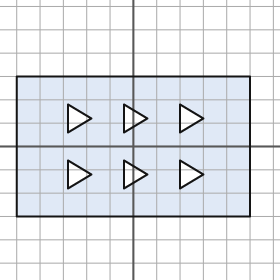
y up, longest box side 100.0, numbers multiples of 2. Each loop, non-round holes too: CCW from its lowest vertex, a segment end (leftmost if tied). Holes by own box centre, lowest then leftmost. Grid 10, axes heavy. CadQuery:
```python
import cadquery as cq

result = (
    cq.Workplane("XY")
    .moveTo(-50.0, -30.0)
    .lineTo(50.0, -30.0)
    .lineTo(50.0, 30.0)
    .lineTo(-50.0, 30.0)
    .close()
    .moveTo(-28.0, -18.0)
    .lineTo(-18.0, -12.0)
    .lineTo(-28.0, -6.0)
    .close()
    .moveTo(-4.0, -18.0)
    .lineTo(6.0, -12.0)
    .lineTo(-4.0, -6.0)
    .close()
    .moveTo(20.0, -18.0)
    .lineTo(30.0, -12.0)
    .lineTo(20.0, -6.0)
    .close()
    .moveTo(-28.0, 6.0)
    .lineTo(-18.0, 12.0)
    .lineTo(-28.0, 18.0)
    .close()
    .moveTo(-4.0, 6.0)
    .lineTo(6.0, 12.0)
    .lineTo(-4.0, 18.0)
    .close()
    .moveTo(20.0, 6.0)
    .lineTo(30.0, 12.0)
    .lineTo(20.0, 18.0)
    .close()
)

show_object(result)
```